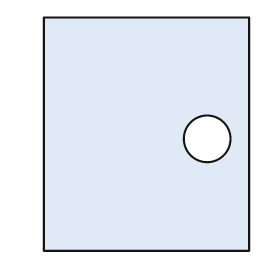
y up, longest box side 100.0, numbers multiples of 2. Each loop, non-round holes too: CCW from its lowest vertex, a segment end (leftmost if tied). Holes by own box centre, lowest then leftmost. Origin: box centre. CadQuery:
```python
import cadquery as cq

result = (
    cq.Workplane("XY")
    .moveTo(-44.0, -50.0)
    .lineTo(44.0, -50.0)
    .lineTo(44.0, 50.0)
    .lineTo(-44.0, 50.0)
    .close()
    .moveTo(26.0, -2.0)
    .circle(10.0)
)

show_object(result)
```